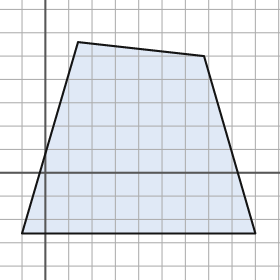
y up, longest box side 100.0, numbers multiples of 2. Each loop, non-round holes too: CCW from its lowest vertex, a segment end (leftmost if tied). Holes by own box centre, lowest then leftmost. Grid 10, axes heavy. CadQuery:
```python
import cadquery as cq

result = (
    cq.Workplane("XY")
    .moveTo(-10.0, -26.0)
    .lineTo(90.0, -26.0)
    .lineTo(68.0, 50.0)
    .lineTo(14.0, 56.0)
    .close()
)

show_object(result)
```